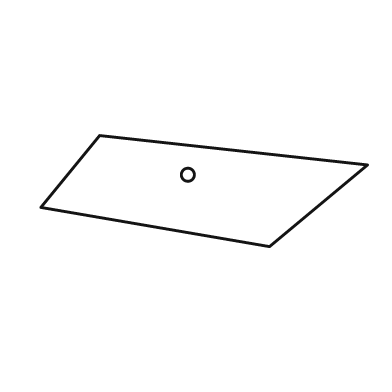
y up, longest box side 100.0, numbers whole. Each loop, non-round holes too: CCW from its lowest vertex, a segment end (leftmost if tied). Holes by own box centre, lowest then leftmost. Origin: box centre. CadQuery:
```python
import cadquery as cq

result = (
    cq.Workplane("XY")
    .moveTo(20.0, -17.0)
    .lineTo(50.0, 8.0)
    .lineTo(-32.0, 17.0)
    .lineTo(-50.0, -5.0)
    .close()
    .moveTo(-5.0, 5.0)
    .circle(2.0)
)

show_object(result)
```